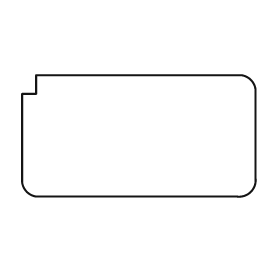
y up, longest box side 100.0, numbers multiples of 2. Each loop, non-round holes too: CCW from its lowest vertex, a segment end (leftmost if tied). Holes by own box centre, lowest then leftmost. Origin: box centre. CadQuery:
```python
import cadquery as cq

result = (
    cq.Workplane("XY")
    .moveTo(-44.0, -26.0)
    .lineTo(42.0, -26.0)
    .threePointArc((48.0, -24.0), (50.0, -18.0))
    .lineTo(50.0, 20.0)
    .threePointArc((48.0, 24.0), (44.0, 26.0))
    .lineTo(-44.0, 26.0)
    .lineTo(-44.0, 18.0)
    .lineTo(-50.0, 18.0)
    .lineTo(-50.0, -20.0)
    .threePointArc((-48.0, -24.0), (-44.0, -26.0))
    .close()
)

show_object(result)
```